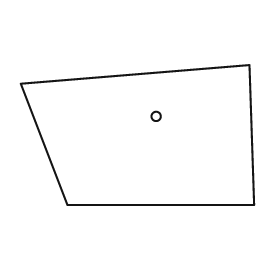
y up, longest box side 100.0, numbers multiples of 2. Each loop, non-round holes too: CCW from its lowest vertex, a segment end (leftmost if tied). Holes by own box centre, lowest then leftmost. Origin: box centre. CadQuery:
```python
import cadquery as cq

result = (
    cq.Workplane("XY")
    .moveTo(-30.0, -30.0)
    .lineTo(50.0, -30.0)
    .lineTo(48.0, 30.0)
    .lineTo(-50.0, 22.0)
    .close()
    .moveTo(8.0, 8.0)
    .circle(2.0)
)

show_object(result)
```